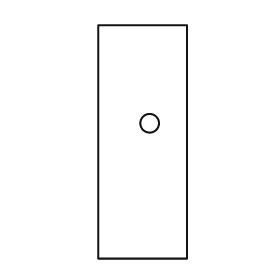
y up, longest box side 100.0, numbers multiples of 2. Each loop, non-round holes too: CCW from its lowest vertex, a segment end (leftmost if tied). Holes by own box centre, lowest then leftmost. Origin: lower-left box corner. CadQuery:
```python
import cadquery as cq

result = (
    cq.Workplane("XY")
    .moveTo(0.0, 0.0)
    .lineTo(38.0, 0.0)
    .lineTo(38.0, 100.0)
    .lineTo(0.0, 100.0)
    .close()
    .moveTo(22.0, 58.0)
    .circle(4.0)
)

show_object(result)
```